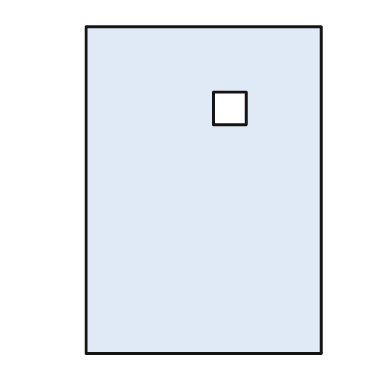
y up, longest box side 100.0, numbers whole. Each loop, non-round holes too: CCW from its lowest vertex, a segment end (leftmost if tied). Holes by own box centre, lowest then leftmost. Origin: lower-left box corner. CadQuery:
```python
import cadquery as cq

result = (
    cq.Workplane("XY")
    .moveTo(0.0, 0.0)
    .lineTo(72.0, 0.0)
    .lineTo(72.0, 100.0)
    .lineTo(0.0, 100.0)
    .close()
    .moveTo(39.0, 70.0)
    .lineTo(49.0, 70.0)
    .lineTo(49.0, 80.0)
    .lineTo(39.0, 80.0)
    .close()
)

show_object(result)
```